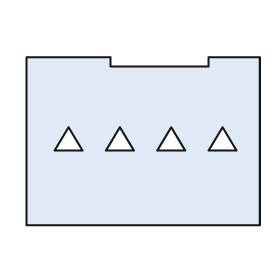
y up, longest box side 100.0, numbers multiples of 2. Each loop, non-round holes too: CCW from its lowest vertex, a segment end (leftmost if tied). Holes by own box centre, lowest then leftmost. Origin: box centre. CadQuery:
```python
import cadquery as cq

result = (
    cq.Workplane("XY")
    .moveTo(-50.0, -36.0)
    .lineTo(50.0, -36.0)
    .lineTo(50.0, 36.0)
    .lineTo(28.0, 36.0)
    .lineTo(28.0, 32.0)
    .lineTo(-14.0, 32.0)
    .lineTo(-14.0, 36.0)
    .lineTo(-50.0, 36.0)
    .close()
    .moveTo(-38.0, -4.0)
    .lineTo(-26.0, -4.0)
    .lineTo(-32.0, 6.0)
    .close()
    .moveTo(-16.0, -4.0)
    .lineTo(-4.0, -4.0)
    .lineTo(-10.0, 6.0)
    .close()
    .moveTo(6.0, -4.0)
    .lineTo(18.0, -4.0)
    .lineTo(12.0, 6.0)
    .close()
    .moveTo(28.0, -4.0)
    .lineTo(40.0, -4.0)
    .lineTo(34.0, 6.0)
    .close()
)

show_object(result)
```